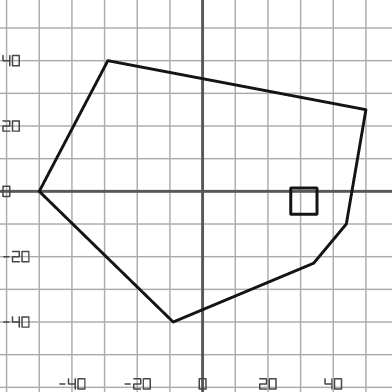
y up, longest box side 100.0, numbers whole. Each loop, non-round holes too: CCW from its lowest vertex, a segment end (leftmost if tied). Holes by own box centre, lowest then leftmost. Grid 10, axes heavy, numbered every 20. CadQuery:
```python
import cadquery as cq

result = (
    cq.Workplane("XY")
    .moveTo(-9.0, -40.0)
    .lineTo(34.0, -22.0)
    .lineTo(44.0, -10.0)
    .lineTo(50.0, 25.0)
    .lineTo(-29.0, 40.0)
    .lineTo(-50.0, 0.0)
    .close()
    .moveTo(27.0, -7.0)
    .lineTo(35.0, -7.0)
    .lineTo(35.0, 1.0)
    .lineTo(27.0, 1.0)
    .close()
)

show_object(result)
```